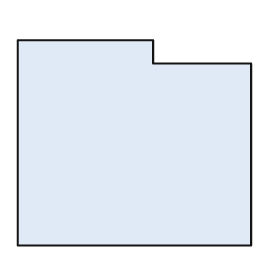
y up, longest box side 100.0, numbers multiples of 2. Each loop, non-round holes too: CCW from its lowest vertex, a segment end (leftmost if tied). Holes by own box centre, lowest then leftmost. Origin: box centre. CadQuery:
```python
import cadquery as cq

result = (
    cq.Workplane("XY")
    .moveTo(-50.0, -44.0)
    .lineTo(50.0, -44.0)
    .lineTo(50.0, 34.0)
    .lineTo(8.0, 34.0)
    .lineTo(8.0, 44.0)
    .lineTo(-50.0, 44.0)
    .close()
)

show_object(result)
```